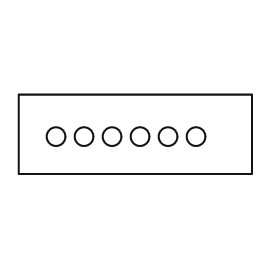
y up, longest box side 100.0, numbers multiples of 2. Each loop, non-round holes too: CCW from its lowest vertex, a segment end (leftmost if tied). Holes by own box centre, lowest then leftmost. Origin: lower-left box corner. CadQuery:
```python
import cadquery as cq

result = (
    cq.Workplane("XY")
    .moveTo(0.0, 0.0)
    .lineTo(100.0, 0.0)
    .lineTo(100.0, 34.0)
    .lineTo(0.0, 34.0)
    .close()
    .moveTo(16.0, 16.0)
    .circle(4.0)
    .moveTo(28.0, 16.0)
    .circle(4.0)
    .moveTo(40.0, 16.0)
    .circle(4.0)
    .moveTo(52.0, 16.0)
    .circle(4.0)
    .moveTo(64.0, 16.0)
    .circle(4.0)
    .moveTo(76.0, 16.0)
    .circle(4.0)
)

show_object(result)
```